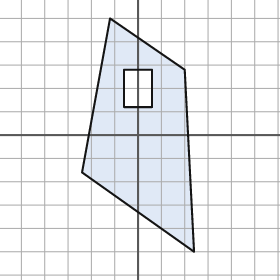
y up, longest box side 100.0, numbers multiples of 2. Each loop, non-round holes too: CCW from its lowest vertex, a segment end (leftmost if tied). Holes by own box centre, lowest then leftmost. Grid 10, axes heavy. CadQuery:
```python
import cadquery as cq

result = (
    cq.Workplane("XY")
    .moveTo(24.0, -50.0)
    .lineTo(20.0, 28.0)
    .lineTo(-12.0, 50.0)
    .lineTo(-24.0, -16.0)
    .close()
    .moveTo(-6.0, 12.0)
    .lineTo(6.0, 12.0)
    .lineTo(6.0, 28.0)
    .lineTo(-6.0, 28.0)
    .close()
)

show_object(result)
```